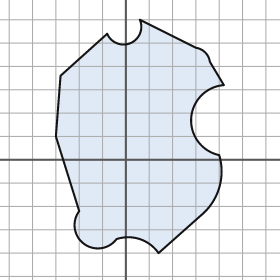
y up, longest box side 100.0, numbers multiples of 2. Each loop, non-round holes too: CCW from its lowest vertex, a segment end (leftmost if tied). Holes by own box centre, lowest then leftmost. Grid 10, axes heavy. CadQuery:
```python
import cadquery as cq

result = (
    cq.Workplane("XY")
    .moveTo(14.0, -40.0)
    .lineTo(32.0, -24.0)
    .threePointArc((40.0, -12.0), (40.0, 2.0))
    .threePointArc((28.0, 18.0), (42.0, 32.0))
    .lineTo(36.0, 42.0)
    .threePointArc((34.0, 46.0), (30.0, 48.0))
    .lineTo(6.0, 60.0)
    .threePointArc((2.0, 50.0), (-8.0, 54.0))
    .lineTo(-28.0, 36.0)
    .lineTo(-30.0, 10.0)
    .lineTo(-20.0, -22.0)
    .threePointArc((-18.0, -36.0), (-4.0, -34.0))
    .threePointArc((6.0, -34.0), (14.0, -40.0))
    .close()
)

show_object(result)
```